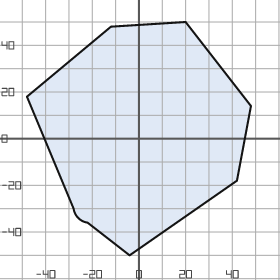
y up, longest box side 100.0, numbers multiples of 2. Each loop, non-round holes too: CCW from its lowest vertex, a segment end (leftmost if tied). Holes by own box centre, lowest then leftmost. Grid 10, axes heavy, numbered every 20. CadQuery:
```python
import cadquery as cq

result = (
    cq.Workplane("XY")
    .moveTo(-4.0, -50.0)
    .lineTo(42.0, -18.0)
    .lineTo(48.0, 14.0)
    .lineTo(20.0, 50.0)
    .lineTo(-12.0, 48.0)
    .lineTo(-48.0, 18.0)
    .lineTo(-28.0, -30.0)
    .threePointArc((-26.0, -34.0), (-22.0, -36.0))
    .close()
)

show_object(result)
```